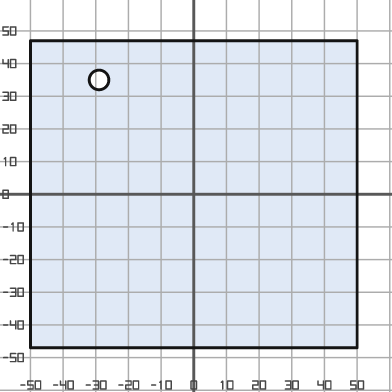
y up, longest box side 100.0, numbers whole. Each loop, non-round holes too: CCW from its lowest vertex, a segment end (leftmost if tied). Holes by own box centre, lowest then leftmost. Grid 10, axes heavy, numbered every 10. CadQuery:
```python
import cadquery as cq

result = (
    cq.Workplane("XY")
    .moveTo(-50.0, -47.0)
    .lineTo(50.0, -47.0)
    .lineTo(50.0, 47.0)
    .lineTo(-50.0, 47.0)
    .close()
    .moveTo(-29.0, 35.0)
    .circle(3.0)
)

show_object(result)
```